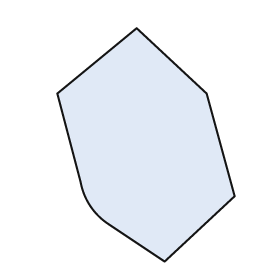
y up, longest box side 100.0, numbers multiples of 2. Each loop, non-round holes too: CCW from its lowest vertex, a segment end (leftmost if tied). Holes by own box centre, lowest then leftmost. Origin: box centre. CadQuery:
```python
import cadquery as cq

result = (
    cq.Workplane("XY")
    .moveTo(8.0, -50.0)
    .lineTo(38.0, -22.0)
    .lineTo(26.0, 22.0)
    .lineTo(-4.0, 50.0)
    .lineTo(-38.0, 22.0)
    .lineTo(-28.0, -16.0)
    .threePointArc((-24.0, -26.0), (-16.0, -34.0))
    .close()
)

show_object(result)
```